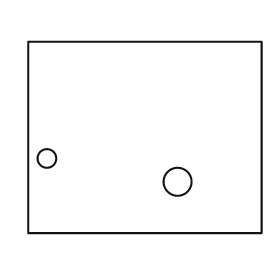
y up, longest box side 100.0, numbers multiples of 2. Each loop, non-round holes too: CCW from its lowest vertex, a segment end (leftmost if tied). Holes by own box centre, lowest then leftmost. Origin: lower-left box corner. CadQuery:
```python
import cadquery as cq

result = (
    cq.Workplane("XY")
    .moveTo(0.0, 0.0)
    .lineTo(100.0, 0.0)
    .lineTo(100.0, 82.0)
    .lineTo(0.0, 82.0)
    .close()
    .moveTo(64.0, 22.0)
    .circle(6.0)
    .moveTo(8.0, 32.0)
    .circle(4.0)
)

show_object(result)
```